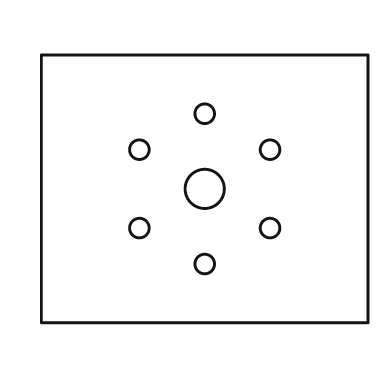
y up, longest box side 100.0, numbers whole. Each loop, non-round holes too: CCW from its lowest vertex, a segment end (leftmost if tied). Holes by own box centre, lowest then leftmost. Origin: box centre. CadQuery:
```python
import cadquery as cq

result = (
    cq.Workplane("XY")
    .moveTo(-50.0, -41.0)
    .lineTo(50.0, -41.0)
    .lineTo(50.0, 41.0)
    .lineTo(-50.0, 41.0)
    .close()
    .moveTo(0.0, -23.0)
    .circle(3.0)
    .moveTo(-20.0, -12.0)
    .circle(3.0)
    .moveTo(20.0, -12.0)
    .circle(3.0)
    .moveTo(0.0, 0.0)
    .circle(6.0)
    .moveTo(-20.0, 12.0)
    .circle(3.0)
    .moveTo(20.0, 12.0)
    .circle(3.0)
    .moveTo(0.0, 23.0)
    .circle(3.0)
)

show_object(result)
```